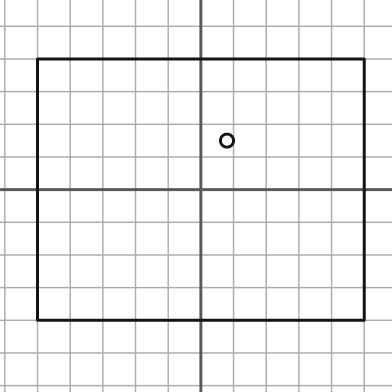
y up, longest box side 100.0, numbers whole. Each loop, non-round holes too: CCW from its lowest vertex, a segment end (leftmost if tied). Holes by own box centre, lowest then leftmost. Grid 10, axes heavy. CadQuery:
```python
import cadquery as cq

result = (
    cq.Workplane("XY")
    .moveTo(-50.0, -40.0)
    .lineTo(50.0, -40.0)
    .lineTo(50.0, 40.0)
    .lineTo(-50.0, 40.0)
    .close()
    .moveTo(8.0, 15.0)
    .circle(2.0)
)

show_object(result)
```